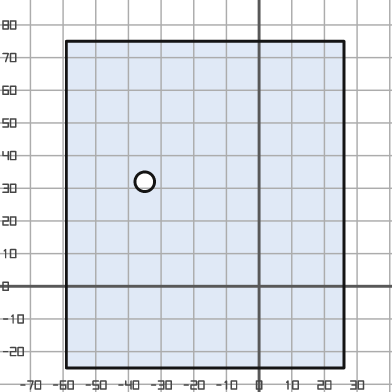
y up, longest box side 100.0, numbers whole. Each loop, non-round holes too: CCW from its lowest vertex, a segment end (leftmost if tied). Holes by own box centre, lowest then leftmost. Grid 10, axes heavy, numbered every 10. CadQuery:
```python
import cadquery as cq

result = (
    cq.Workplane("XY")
    .moveTo(-59.0, -25.0)
    .lineTo(26.0, -25.0)
    .lineTo(26.0, 75.0)
    .lineTo(-59.0, 75.0)
    .close()
    .moveTo(-35.0, 32.0)
    .circle(3.0)
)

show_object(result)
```